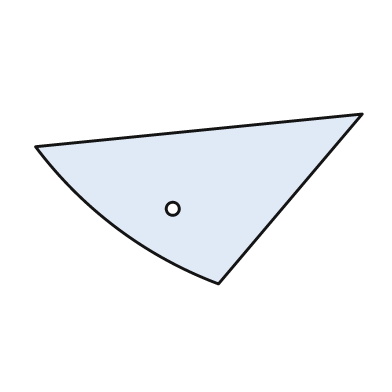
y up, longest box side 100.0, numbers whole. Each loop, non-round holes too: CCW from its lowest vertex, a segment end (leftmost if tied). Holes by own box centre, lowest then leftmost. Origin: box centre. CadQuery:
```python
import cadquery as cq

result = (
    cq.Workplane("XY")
    .moveTo(6.0, -26.0)
    .lineTo(50.0, 26.0)
    .lineTo(-50.0, 16.0)
    .threePointArc((-25.0, -9.0), (6.0, -26.0))
    .close()
    .moveTo(-8.0, -3.0)
    .circle(2.0)
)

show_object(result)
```